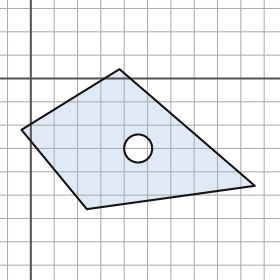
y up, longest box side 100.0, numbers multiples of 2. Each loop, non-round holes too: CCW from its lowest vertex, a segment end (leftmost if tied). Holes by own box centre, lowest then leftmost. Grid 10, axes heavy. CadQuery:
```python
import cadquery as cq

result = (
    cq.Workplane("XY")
    .moveTo(24.0, -56.0)
    .lineTo(96.0, -46.0)
    .lineTo(38.0, 4.0)
    .lineTo(-4.0, -22.0)
    .close()
    .moveTo(46.0, -30.0)
    .circle(6.0)
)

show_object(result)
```